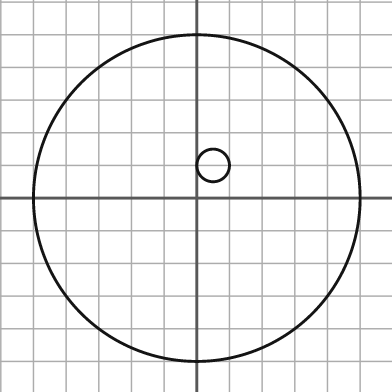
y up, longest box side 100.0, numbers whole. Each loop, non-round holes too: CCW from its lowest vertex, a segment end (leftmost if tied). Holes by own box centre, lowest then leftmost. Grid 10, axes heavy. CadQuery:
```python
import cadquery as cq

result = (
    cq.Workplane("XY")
    .moveTo(0.0, 0.0)
    .circle(50.0)
    .moveTo(5.0, 10.0)
    .circle(5.0)
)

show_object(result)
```